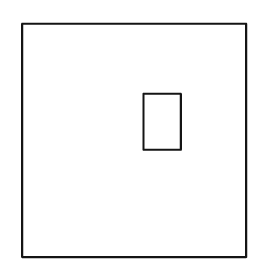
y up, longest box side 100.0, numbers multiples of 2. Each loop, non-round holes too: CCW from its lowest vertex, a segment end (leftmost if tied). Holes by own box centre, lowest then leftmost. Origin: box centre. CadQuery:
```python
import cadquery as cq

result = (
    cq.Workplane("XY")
    .moveTo(-48.0, -50.0)
    .lineTo(48.0, -50.0)
    .lineTo(48.0, 50.0)
    .lineTo(-48.0, 50.0)
    .close()
    .moveTo(4.0, -4.0)
    .lineTo(20.0, -4.0)
    .lineTo(20.0, 20.0)
    .lineTo(4.0, 20.0)
    .close()
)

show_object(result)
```